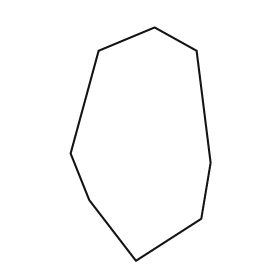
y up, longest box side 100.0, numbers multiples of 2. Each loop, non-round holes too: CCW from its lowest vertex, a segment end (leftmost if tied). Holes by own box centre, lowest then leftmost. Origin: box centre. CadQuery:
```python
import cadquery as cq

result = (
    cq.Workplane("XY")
    .moveTo(-2.0, -50.0)
    .lineTo(26.0, -32.0)
    .lineTo(30.0, -8.0)
    .lineTo(24.0, 40.0)
    .lineTo(6.0, 50.0)
    .lineTo(-18.0, 40.0)
    .lineTo(-30.0, -4.0)
    .lineTo(-22.0, -24.0)
    .close()
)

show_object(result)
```